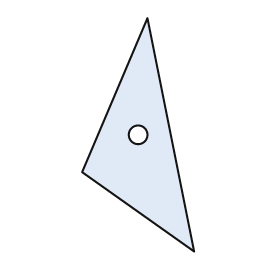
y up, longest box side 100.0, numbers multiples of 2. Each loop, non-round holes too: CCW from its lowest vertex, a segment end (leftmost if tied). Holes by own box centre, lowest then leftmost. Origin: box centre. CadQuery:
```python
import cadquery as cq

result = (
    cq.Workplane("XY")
    .moveTo(24.0, -50.0)
    .lineTo(4.0, 50.0)
    .lineTo(-24.0, -16.0)
    .close()
    .moveTo(0.0, 0.0)
    .circle(4.0)
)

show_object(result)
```